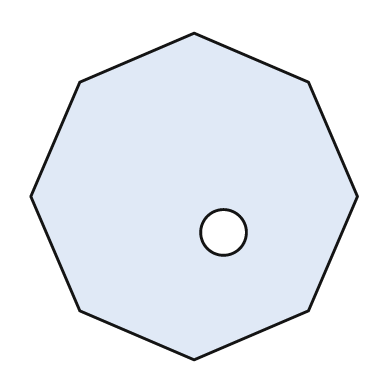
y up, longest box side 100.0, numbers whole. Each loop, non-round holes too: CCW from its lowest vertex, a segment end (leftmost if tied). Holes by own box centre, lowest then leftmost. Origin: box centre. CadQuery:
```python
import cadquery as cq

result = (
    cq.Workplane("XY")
    .moveTo(0.0, -50.0)
    .lineTo(35.0, -35.0)
    .lineTo(50.0, 0.0)
    .lineTo(35.0, 35.0)
    .lineTo(0.0, 50.0)
    .lineTo(-35.0, 35.0)
    .lineTo(-50.0, 0.0)
    .lineTo(-35.0, -35.0)
    .close()
    .moveTo(9.0, -11.0)
    .circle(7.0)
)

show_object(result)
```